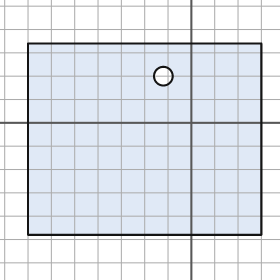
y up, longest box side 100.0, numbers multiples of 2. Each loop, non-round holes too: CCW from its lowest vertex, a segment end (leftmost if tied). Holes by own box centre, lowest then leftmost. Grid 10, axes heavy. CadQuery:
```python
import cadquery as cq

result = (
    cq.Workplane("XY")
    .moveTo(-70.0, -48.0)
    .lineTo(30.0, -48.0)
    .lineTo(30.0, 34.0)
    .lineTo(-70.0, 34.0)
    .close()
    .moveTo(-12.0, 20.0)
    .circle(4.0)
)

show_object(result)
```